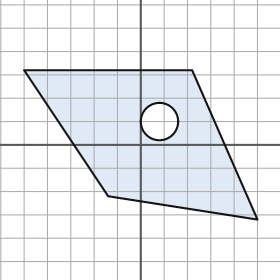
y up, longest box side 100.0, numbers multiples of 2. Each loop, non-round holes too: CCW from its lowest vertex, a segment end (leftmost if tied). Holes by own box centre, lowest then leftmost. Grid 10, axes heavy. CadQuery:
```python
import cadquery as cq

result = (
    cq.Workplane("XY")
    .moveTo(50.0, -32.0)
    .lineTo(22.0, 32.0)
    .lineTo(-50.0, 32.0)
    .lineTo(-14.0, -22.0)
    .close()
    .moveTo(8.0, 10.0)
    .circle(8.0)
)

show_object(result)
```